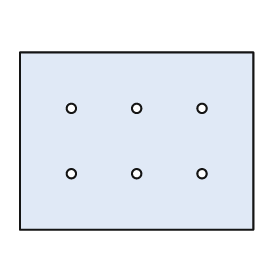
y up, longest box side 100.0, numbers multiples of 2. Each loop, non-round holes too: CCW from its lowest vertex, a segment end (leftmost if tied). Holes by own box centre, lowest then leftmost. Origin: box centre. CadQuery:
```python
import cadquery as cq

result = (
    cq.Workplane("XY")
    .moveTo(-50.0, -38.0)
    .lineTo(50.0, -38.0)
    .lineTo(50.0, 38.0)
    .lineTo(-50.0, 38.0)
    .close()
    .moveTo(-28.0, -14.0)
    .circle(2.0)
    .moveTo(0.0, -14.0)
    .circle(2.0)
    .moveTo(28.0, -14.0)
    .circle(2.0)
    .moveTo(-28.0, 14.0)
    .circle(2.0)
    .moveTo(0.0, 14.0)
    .circle(2.0)
    .moveTo(28.0, 14.0)
    .circle(2.0)
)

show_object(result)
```